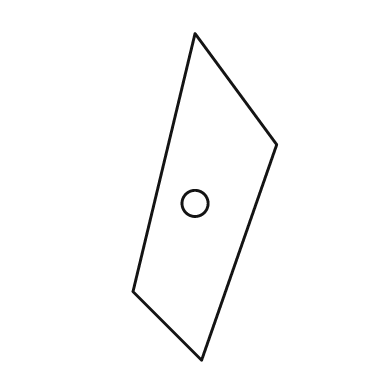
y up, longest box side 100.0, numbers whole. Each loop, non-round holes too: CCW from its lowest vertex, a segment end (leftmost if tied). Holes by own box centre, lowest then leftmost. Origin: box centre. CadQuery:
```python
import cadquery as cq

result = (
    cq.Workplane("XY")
    .moveTo(-1.0, -50.0)
    .lineTo(22.0, 16.0)
    .lineTo(-3.0, 50.0)
    .lineTo(-22.0, -29.0)
    .close()
    .moveTo(-3.0, -2.0)
    .circle(4.0)
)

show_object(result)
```